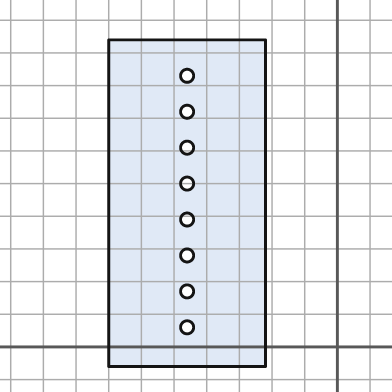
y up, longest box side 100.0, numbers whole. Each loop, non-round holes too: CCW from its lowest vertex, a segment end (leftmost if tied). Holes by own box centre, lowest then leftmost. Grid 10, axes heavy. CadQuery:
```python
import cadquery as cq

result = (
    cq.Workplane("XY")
    .moveTo(-70.0, -6.0)
    .lineTo(-22.0, -6.0)
    .lineTo(-22.0, 94.0)
    .lineTo(-70.0, 94.0)
    .close()
    .moveTo(-46.0, 6.0)
    .circle(2.0)
    .moveTo(-46.0, 17.0)
    .circle(2.0)
    .moveTo(-46.0, 28.0)
    .circle(2.0)
    .moveTo(-46.0, 39.0)
    .circle(2.0)
    .moveTo(-46.0, 50.0)
    .circle(2.0)
    .moveTo(-46.0, 61.0)
    .circle(2.0)
    .moveTo(-46.0, 72.0)
    .circle(2.0)
    .moveTo(-46.0, 83.0)
    .circle(2.0)
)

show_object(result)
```